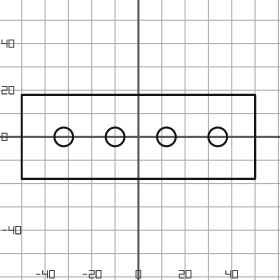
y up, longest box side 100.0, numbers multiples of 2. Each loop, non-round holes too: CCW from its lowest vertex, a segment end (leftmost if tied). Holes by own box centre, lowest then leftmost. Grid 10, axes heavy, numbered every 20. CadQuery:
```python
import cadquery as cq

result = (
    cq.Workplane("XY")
    .moveTo(-50.0, -18.0)
    .lineTo(50.0, -18.0)
    .lineTo(50.0, 18.0)
    .lineTo(-50.0, 18.0)
    .close()
    .moveTo(-32.0, 0.0)
    .circle(4.0)
    .moveTo(-10.0, 0.0)
    .circle(4.0)
    .moveTo(12.0, 0.0)
    .circle(4.0)
    .moveTo(34.0, 0.0)
    .circle(4.0)
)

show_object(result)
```